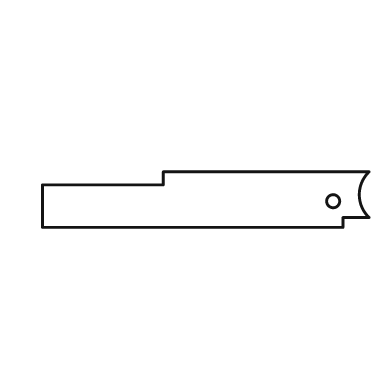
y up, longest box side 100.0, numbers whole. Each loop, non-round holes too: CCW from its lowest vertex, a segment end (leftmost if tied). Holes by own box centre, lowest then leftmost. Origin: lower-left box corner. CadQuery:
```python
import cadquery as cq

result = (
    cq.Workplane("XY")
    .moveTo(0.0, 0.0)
    .lineTo(92.0, 0.0)
    .lineTo(92.0, 3.0)
    .lineTo(100.0, 3.0)
    .threePointArc((97.0, 10.0), (100.0, 17.0))
    .lineTo(37.0, 17.0)
    .lineTo(37.0, 13.0)
    .lineTo(0.0, 13.0)
    .close()
    .moveTo(89.0, 8.0)
    .circle(2.0)
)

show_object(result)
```